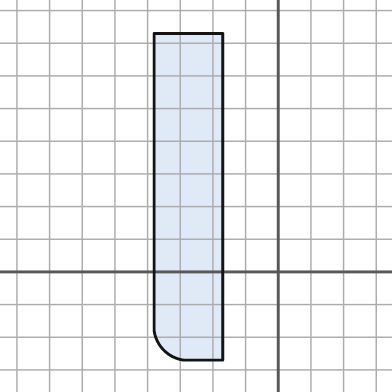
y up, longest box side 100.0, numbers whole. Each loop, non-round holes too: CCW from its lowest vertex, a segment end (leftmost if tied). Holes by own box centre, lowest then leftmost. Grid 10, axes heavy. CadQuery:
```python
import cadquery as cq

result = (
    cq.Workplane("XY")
    .moveTo(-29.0, -27.0)
    .lineTo(-17.0, -27.0)
    .lineTo(-17.0, 73.0)
    .lineTo(-38.0, 73.0)
    .lineTo(-38.0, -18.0)
    .threePointArc((-35.0, -24.0), (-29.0, -27.0))
    .close()
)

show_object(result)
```